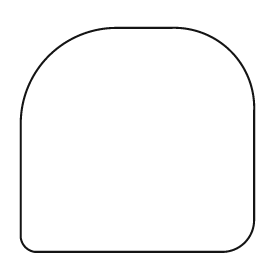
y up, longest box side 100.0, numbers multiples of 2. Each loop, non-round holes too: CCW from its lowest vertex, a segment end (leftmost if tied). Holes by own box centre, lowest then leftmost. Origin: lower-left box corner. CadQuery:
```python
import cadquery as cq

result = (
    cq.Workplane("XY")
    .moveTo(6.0, 0.0)
    .lineTo(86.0, 0.0)
    .threePointArc((96.0, 4.0), (100.0, 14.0))
    .lineTo(100.0, 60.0)
    .threePointArc((90.0, 86.0), (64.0, 96.0))
    .lineTo(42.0, 96.0)
    .threePointArc((12.0, 84.0), (0.0, 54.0))
    .lineTo(0.0, 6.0)
    .threePointArc((2.0, 2.0), (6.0, 0.0))
    .close()
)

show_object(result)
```